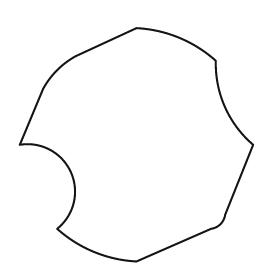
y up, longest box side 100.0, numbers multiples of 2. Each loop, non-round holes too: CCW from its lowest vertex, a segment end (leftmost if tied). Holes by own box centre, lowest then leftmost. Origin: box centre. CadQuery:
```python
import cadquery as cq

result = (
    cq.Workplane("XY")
    .moveTo(0.0, -50.0)
    .lineTo(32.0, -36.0)
    .threePointArc((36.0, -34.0), (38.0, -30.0))
    .lineTo(50.0, 0.0)
    .threePointArc((38.0, 16.0), (34.0, 36.0))
    .threePointArc((18.0, 46.0), (0.0, 50.0))
    .lineTo(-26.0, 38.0)
    .threePointArc((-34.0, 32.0), (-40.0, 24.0))
    .lineTo(-50.0, 0.0)
    .threePointArc((-28.0, -12.0), (-34.0, -36.0))
    .threePointArc((-18.0, -46.0), (0.0, -50.0))
    .close()
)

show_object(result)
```